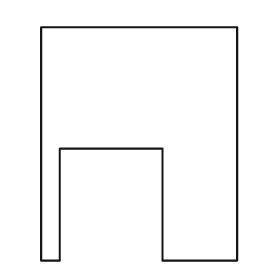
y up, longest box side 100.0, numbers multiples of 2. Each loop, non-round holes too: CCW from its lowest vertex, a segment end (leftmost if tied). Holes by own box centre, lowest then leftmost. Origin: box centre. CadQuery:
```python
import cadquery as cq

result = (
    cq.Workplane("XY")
    .moveTo(-42.0, -50.0)
    .lineTo(-34.0, -50.0)
    .lineTo(-34.0, -2.0)
    .lineTo(10.0, -2.0)
    .lineTo(10.0, -50.0)
    .lineTo(42.0, -50.0)
    .lineTo(42.0, 50.0)
    .lineTo(-42.0, 50.0)
    .close()
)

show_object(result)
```